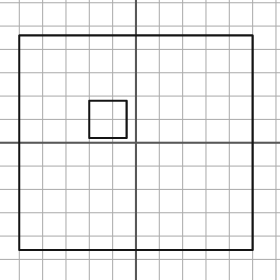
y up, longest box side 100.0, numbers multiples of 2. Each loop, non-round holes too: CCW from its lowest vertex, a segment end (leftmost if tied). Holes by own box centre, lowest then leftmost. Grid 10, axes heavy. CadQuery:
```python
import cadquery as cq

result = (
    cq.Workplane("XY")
    .moveTo(-50.0, -46.0)
    .lineTo(50.0, -46.0)
    .lineTo(50.0, 46.0)
    .lineTo(-50.0, 46.0)
    .close()
    .moveTo(-20.0, 2.0)
    .lineTo(-4.0, 2.0)
    .lineTo(-4.0, 18.0)
    .lineTo(-20.0, 18.0)
    .close()
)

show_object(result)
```